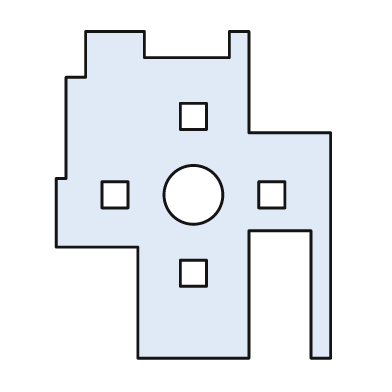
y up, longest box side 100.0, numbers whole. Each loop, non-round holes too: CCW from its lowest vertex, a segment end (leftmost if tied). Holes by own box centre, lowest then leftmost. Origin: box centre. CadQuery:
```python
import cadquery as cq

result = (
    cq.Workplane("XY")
    .moveTo(-17.0, -50.0)
    .lineTo(17.0, -50.0)
    .lineTo(17.0, -11.0)
    .lineTo(36.0, -11.0)
    .lineTo(36.0, -50.0)
    .lineTo(42.0, -50.0)
    .lineTo(42.0, 19.0)
    .lineTo(17.0, 19.0)
    .lineTo(17.0, 50.0)
    .lineTo(11.0, 50.0)
    .lineTo(11.0, 42.0)
    .lineTo(-15.0, 42.0)
    .lineTo(-15.0, 50.0)
    .lineTo(-33.0, 50.0)
    .lineTo(-33.0, 36.0)
    .lineTo(-39.0, 36.0)
    .lineTo(-39.0, 5.0)
    .lineTo(-42.0, 5.0)
    .lineTo(-42.0, -16.0)
    .lineTo(-17.0, -16.0)
    .close()
    .moveTo(-4.0, -28.0)
    .lineTo(4.0, -28.0)
    .lineTo(4.0, -20.0)
    .lineTo(-4.0, -20.0)
    .close()
    .moveTo(-28.0, -4.0)
    .lineTo(-20.0, -4.0)
    .lineTo(-20.0, 4.0)
    .lineTo(-28.0, 4.0)
    .close()
    .moveTo(0.0, 0.0)
    .circle(9.0)
    .moveTo(20.0, -4.0)
    .lineTo(28.0, -4.0)
    .lineTo(28.0, 4.0)
    .lineTo(20.0, 4.0)
    .close()
    .moveTo(-4.0, 20.0)
    .lineTo(4.0, 20.0)
    .lineTo(4.0, 28.0)
    .lineTo(-4.0, 28.0)
    .close()
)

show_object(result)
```